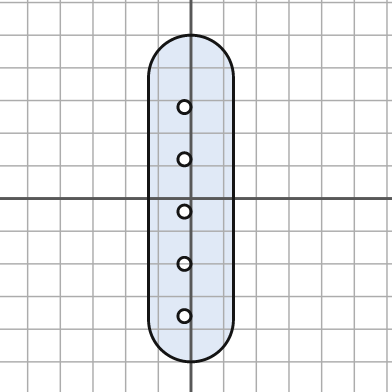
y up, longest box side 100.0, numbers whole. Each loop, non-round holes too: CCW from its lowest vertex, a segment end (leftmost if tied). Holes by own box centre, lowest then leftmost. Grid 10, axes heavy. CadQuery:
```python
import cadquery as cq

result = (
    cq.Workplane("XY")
    .moveTo(-13.0, -37.0)
    .threePointArc((0.0, -50.0), (13.0, -37.0))
    .lineTo(13.0, 37.0)
    .threePointArc((0.0, 50.0), (-13.0, 37.0))
    .close()
    .moveTo(-2.0, -36.0)
    .circle(2.0)
    .moveTo(-2.0, -20.0)
    .circle(2.0)
    .moveTo(-2.0, -4.0)
    .circle(2.0)
    .moveTo(-2.0, 12.0)
    .circle(2.0)
    .moveTo(-2.0, 28.0)
    .circle(2.0)
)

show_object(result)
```